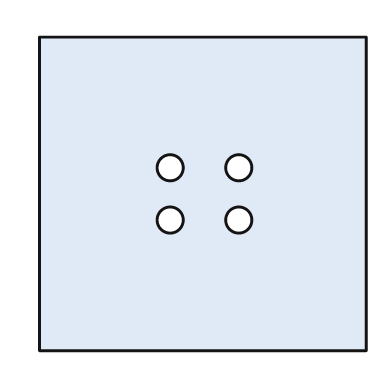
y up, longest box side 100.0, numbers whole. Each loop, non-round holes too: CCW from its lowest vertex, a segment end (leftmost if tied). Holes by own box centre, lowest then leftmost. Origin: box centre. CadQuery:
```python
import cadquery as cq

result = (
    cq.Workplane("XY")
    .moveTo(-50.0, -48.0)
    .lineTo(50.0, -48.0)
    .lineTo(50.0, 48.0)
    .lineTo(-50.0, 48.0)
    .close()
    .moveTo(-10.0, -8.0)
    .circle(4.0)
    .moveTo(11.0, -8.0)
    .circle(4.0)
    .moveTo(-10.0, 8.0)
    .circle(4.0)
    .moveTo(11.0, 8.0)
    .circle(4.0)
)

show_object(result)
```